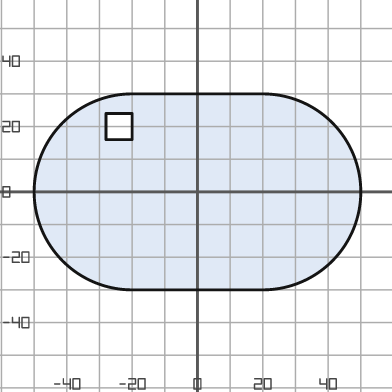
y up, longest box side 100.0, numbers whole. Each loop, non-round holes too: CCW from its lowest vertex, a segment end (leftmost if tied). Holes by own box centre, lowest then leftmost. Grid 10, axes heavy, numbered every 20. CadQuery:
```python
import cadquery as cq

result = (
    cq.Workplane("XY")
    .moveTo(-20.0, -30.0)
    .lineTo(20.0, -30.0)
    .threePointArc((50.0, 0.0), (20.0, 30.0))
    .lineTo(-20.0, 30.0)
    .threePointArc((-50.0, 0.0), (-20.0, -30.0))
    .close()
    .moveTo(-28.0, 16.0)
    .lineTo(-20.0, 16.0)
    .lineTo(-20.0, 24.0)
    .lineTo(-28.0, 24.0)
    .close()
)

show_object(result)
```